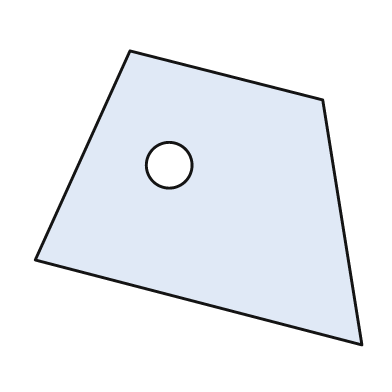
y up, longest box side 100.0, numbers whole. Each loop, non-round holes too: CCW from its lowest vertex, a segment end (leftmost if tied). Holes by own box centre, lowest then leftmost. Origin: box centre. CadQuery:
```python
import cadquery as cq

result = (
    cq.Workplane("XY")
    .moveTo(50.0, -45.0)
    .lineTo(38.0, 30.0)
    .lineTo(-21.0, 45.0)
    .lineTo(-50.0, -19.0)
    .close()
    .moveTo(-9.0, 10.0)
    .circle(7.0)
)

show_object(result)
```